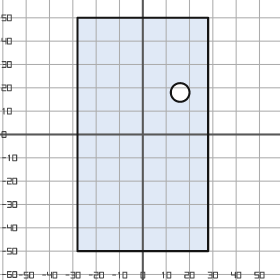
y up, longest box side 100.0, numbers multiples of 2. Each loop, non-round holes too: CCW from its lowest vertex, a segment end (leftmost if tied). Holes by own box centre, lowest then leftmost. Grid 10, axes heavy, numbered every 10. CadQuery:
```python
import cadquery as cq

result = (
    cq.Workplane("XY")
    .moveTo(-28.0, -50.0)
    .lineTo(28.0, -50.0)
    .lineTo(28.0, 50.0)
    .lineTo(-28.0, 50.0)
    .close()
    .moveTo(16.0, 18.0)
    .circle(4.0)
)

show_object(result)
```